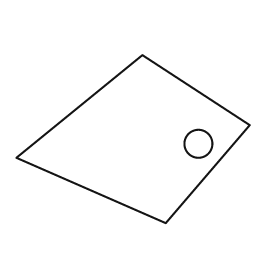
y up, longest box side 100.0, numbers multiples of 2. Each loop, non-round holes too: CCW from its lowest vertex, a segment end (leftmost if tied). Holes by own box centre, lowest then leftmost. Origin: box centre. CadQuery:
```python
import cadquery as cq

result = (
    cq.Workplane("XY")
    .moveTo(14.0, -36.0)
    .lineTo(50.0, 6.0)
    .lineTo(4.0, 36.0)
    .lineTo(-50.0, -8.0)
    .close()
    .moveTo(28.0, -2.0)
    .circle(6.0)
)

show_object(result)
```